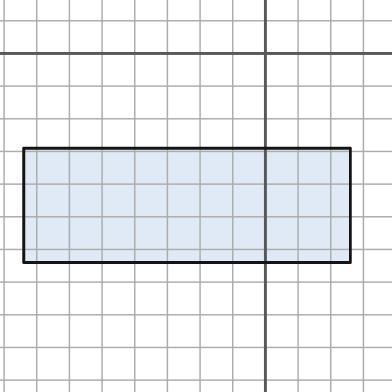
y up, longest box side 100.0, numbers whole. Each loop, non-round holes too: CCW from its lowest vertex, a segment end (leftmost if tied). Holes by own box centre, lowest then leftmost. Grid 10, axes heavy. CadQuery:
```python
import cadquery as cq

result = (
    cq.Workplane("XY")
    .moveTo(-74.0, -64.0)
    .lineTo(26.0, -64.0)
    .lineTo(26.0, -29.0)
    .lineTo(-74.0, -29.0)
    .close()
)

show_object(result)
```